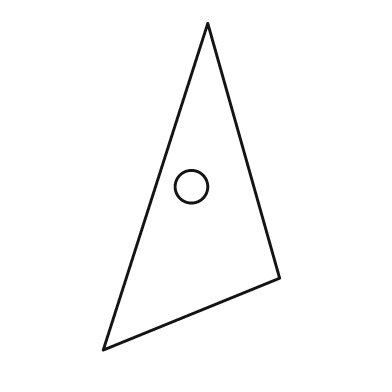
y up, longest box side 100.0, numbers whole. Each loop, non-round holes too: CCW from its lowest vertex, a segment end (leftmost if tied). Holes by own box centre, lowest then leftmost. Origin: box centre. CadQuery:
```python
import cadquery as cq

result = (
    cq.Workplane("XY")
    .moveTo(-27.0, -50.0)
    .lineTo(27.0, -28.0)
    .lineTo(5.0, 50.0)
    .close()
    .moveTo(0.0, 0.0)
    .circle(5.0)
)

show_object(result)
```